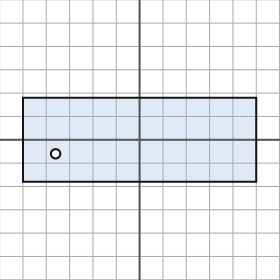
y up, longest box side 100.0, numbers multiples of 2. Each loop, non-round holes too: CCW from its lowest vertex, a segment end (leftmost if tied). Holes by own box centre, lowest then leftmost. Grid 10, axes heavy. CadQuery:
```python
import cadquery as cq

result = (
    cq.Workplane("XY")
    .moveTo(-50.0, -18.0)
    .lineTo(50.0, -18.0)
    .lineTo(50.0, 18.0)
    .lineTo(-50.0, 18.0)
    .close()
    .moveTo(-36.0, -6.0)
    .circle(2.0)
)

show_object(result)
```